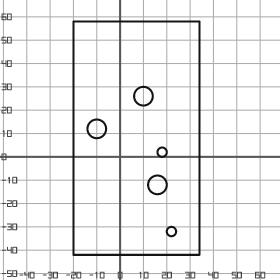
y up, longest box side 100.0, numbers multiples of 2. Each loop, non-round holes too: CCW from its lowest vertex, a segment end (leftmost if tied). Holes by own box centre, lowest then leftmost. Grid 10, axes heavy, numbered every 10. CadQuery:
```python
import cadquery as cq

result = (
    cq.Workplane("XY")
    .moveTo(-20.0, -42.0)
    .lineTo(34.0, -42.0)
    .lineTo(34.0, 58.0)
    .lineTo(-20.0, 58.0)
    .close()
    .moveTo(22.0, -32.0)
    .circle(2.0)
    .moveTo(16.0, -12.0)
    .circle(4.0)
    .moveTo(18.0, 2.0)
    .circle(2.0)
    .moveTo(-10.0, 12.0)
    .circle(4.0)
    .moveTo(10.0, 26.0)
    .circle(4.0)
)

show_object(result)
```